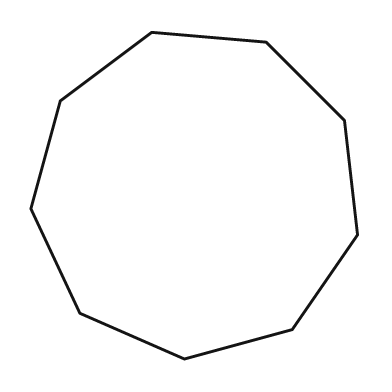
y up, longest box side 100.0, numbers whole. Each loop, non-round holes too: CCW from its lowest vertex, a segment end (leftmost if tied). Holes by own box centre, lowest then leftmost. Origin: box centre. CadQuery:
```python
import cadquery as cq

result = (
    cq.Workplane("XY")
    .moveTo(-3.0, -50.0)
    .lineTo(30.0, -41.0)
    .lineTo(50.0, -12.0)
    .lineTo(46.0, 23.0)
    .lineTo(22.0, 47.0)
    .lineTo(-13.0, 50.0)
    .lineTo(-41.0, 29.0)
    .lineTo(-50.0, -4.0)
    .lineTo(-35.0, -36.0)
    .close()
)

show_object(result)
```